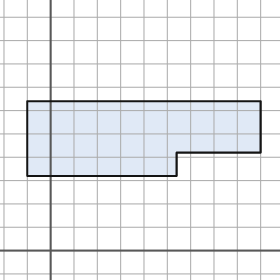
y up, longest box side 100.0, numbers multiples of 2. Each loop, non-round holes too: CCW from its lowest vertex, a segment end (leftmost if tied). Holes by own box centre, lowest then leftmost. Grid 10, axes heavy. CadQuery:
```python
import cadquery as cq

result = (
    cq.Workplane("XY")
    .moveTo(-10.0, 32.0)
    .lineTo(54.0, 32.0)
    .lineTo(54.0, 42.0)
    .lineTo(90.0, 42.0)
    .lineTo(90.0, 64.0)
    .lineTo(-10.0, 64.0)
    .close()
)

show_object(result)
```